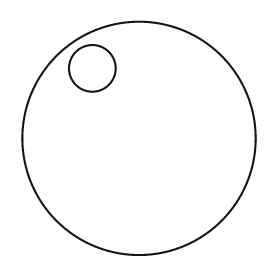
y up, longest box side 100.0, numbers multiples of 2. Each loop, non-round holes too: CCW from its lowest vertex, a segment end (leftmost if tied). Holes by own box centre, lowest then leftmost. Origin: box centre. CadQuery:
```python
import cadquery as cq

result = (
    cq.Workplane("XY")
    .moveTo(0.0, 0.0)
    .circle(50.0)
    .moveTo(-20.0, 30.0)
    .circle(10.0)
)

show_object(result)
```